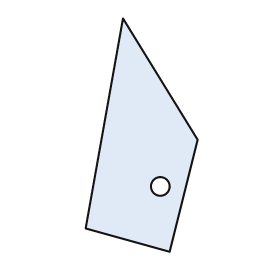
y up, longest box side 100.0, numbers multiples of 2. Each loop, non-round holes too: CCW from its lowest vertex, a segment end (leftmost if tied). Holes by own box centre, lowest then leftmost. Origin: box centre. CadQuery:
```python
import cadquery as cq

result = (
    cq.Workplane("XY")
    .moveTo(12.0, -50.0)
    .lineTo(24.0, -2.0)
    .lineTo(-8.0, 50.0)
    .lineTo(-24.0, -40.0)
    .close()
    .moveTo(8.0, -22.0)
    .circle(4.0)
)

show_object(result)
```